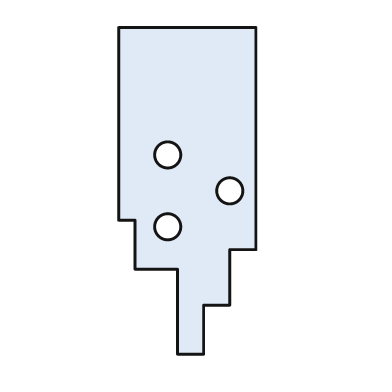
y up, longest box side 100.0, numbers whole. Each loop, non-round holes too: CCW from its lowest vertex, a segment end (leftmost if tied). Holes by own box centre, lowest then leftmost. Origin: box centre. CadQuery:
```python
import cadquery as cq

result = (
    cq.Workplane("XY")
    .moveTo(-3.0, -50.0)
    .lineTo(5.0, -50.0)
    .lineTo(5.0, -35.0)
    .lineTo(13.0, -35.0)
    .lineTo(13.0, -18.0)
    .lineTo(21.0, -18.0)
    .lineTo(21.0, 50.0)
    .lineTo(-21.0, 50.0)
    .lineTo(-21.0, -9.0)
    .lineTo(-16.0, -9.0)
    .lineTo(-16.0, -24.0)
    .lineTo(-3.0, -24.0)
    .close()
    .moveTo(-6.0, -11.0)
    .circle(4.0)
    .moveTo(13.0, 0.0)
    .circle(4.0)
    .moveTo(-6.0, 11.0)
    .circle(4.0)
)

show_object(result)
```